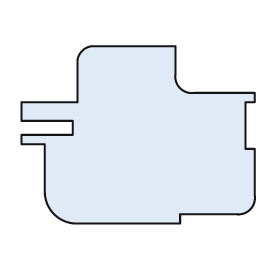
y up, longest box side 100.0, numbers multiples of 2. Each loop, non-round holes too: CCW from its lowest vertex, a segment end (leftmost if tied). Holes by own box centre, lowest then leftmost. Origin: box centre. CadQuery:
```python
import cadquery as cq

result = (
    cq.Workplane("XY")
    .moveTo(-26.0, -38.0)
    .lineTo(18.0, -38.0)
    .lineTo(18.0, -34.0)
    .lineTo(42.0, -34.0)
    .threePointArc((48.0, -32.0), (50.0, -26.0))
    .lineTo(50.0, -6.0)
    .lineTo(46.0, -6.0)
    .lineTo(46.0, 14.0)
    .lineTo(50.0, 14.0)
    .lineTo(50.0, 18.0)
    .lineTo(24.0, 18.0)
    .threePointArc((18.0, 20.0), (16.0, 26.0))
    .lineTo(16.0, 38.0)
    .lineTo(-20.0, 38.0)
    .threePointArc((-24.0, 36.0), (-26.0, 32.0))
    .lineTo(-26.0, 14.0)
    .lineTo(-50.0, 14.0)
    .lineTo(-50.0, 6.0)
    .lineTo(-28.0, 6.0)
    .lineTo(-28.0, 0.0)
    .lineTo(-50.0, 0.0)
    .lineTo(-50.0, -4.0)
    .lineTo(-40.0, -4.0)
    .lineTo(-40.0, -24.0)
    .threePointArc((-36.0, -34.0), (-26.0, -38.0))
    .close()
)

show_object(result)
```